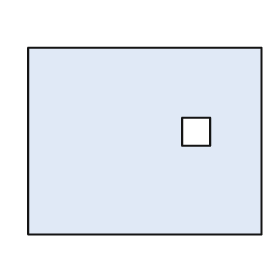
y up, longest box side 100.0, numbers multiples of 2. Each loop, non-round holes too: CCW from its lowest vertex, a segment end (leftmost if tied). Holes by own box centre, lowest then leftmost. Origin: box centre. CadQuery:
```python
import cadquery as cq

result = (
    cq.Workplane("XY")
    .moveTo(-50.0, -40.0)
    .lineTo(50.0, -40.0)
    .lineTo(50.0, 40.0)
    .lineTo(-50.0, 40.0)
    .close()
    .moveTo(16.0, -2.0)
    .lineTo(28.0, -2.0)
    .lineTo(28.0, 10.0)
    .lineTo(16.0, 10.0)
    .close()
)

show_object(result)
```